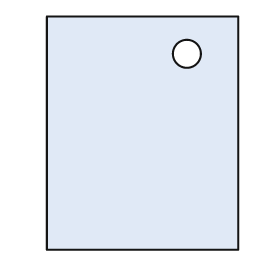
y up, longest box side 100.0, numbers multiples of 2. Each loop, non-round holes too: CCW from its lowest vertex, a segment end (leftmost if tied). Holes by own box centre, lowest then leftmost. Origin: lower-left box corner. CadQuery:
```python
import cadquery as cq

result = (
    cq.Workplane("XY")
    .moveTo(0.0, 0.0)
    .lineTo(82.0, 0.0)
    .lineTo(82.0, 100.0)
    .lineTo(0.0, 100.0)
    .close()
    .moveTo(60.0, 84.0)
    .circle(6.0)
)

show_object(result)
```